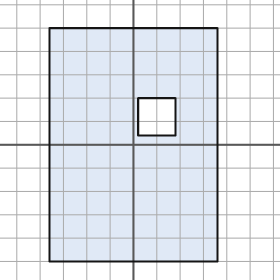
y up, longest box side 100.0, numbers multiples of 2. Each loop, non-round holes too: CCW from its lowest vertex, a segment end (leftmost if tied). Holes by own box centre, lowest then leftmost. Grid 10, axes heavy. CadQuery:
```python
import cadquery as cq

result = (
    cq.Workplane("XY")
    .moveTo(-36.0, -50.0)
    .lineTo(36.0, -50.0)
    .lineTo(36.0, 50.0)
    .lineTo(-36.0, 50.0)
    .close()
    .moveTo(2.0, 4.0)
    .lineTo(18.0, 4.0)
    .lineTo(18.0, 20.0)
    .lineTo(2.0, 20.0)
    .close()
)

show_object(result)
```